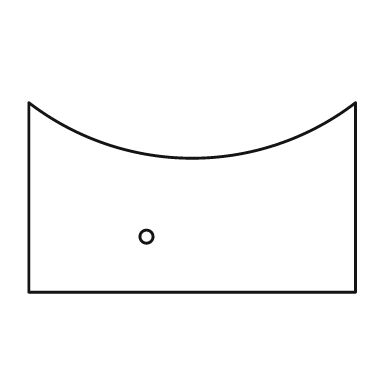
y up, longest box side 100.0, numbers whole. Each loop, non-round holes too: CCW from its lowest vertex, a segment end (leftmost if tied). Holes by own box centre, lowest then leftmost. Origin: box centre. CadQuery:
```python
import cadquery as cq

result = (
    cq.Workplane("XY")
    .moveTo(-50.0, -29.0)
    .lineTo(50.0, -29.0)
    .lineTo(50.0, 29.0)
    .threePointArc((0.0, 12.0), (-50.0, 29.0))
    .close()
    .moveTo(-14.0, -12.0)
    .circle(2.0)
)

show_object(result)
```